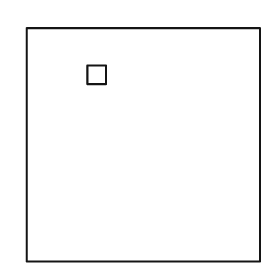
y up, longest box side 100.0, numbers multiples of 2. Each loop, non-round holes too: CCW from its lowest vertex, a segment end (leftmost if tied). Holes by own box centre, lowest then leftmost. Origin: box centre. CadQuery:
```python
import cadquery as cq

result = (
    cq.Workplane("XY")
    .moveTo(-50.0, -50.0)
    .lineTo(50.0, -50.0)
    .lineTo(50.0, 50.0)
    .lineTo(-50.0, 50.0)
    .close()
    .moveTo(-24.0, 26.0)
    .lineTo(-16.0, 26.0)
    .lineTo(-16.0, 34.0)
    .lineTo(-24.0, 34.0)
    .close()
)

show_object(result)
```